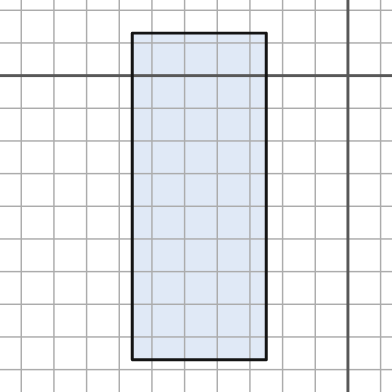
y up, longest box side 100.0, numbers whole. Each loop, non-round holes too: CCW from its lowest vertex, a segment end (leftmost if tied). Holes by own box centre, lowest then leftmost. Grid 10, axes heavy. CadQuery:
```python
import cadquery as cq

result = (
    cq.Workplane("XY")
    .moveTo(-66.0, -87.0)
    .lineTo(-25.0, -87.0)
    .lineTo(-25.0, 13.0)
    .lineTo(-66.0, 13.0)
    .close()
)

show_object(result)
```